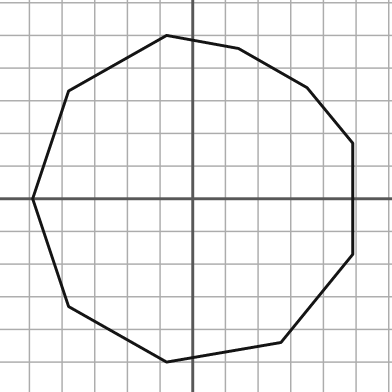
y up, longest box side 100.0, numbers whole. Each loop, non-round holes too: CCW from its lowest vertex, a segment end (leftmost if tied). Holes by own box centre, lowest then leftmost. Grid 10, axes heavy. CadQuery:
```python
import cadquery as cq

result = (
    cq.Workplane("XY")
    .moveTo(-8.0, -50.0)
    .lineTo(27.0, -44.0)
    .lineTo(49.0, -17.0)
    .lineTo(49.0, 17.0)
    .lineTo(35.0, 34.0)
    .lineTo(14.0, 46.0)
    .lineTo(-8.0, 50.0)
    .lineTo(-38.0, 33.0)
    .lineTo(-49.0, 0.0)
    .lineTo(-38.0, -33.0)
    .close()
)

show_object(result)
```